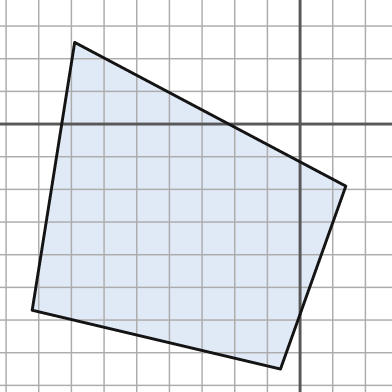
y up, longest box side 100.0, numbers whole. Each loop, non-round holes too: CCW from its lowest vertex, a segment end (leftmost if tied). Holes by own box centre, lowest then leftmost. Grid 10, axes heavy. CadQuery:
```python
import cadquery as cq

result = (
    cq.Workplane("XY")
    .moveTo(-6.0, -75.0)
    .lineTo(14.0, -19.0)
    .lineTo(-69.0, 25.0)
    .lineTo(-82.0, -57.0)
    .close()
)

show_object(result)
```